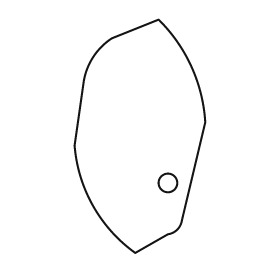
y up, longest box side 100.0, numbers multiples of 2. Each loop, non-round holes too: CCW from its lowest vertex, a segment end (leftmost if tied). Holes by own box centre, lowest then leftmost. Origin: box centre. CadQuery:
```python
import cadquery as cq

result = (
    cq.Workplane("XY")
    .moveTo(-2.0, -50.0)
    .lineTo(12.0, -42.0)
    .threePointArc((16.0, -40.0), (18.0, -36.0))
    .lineTo(28.0, 6.0)
    .threePointArc((22.0, 30.0), (8.0, 50.0))
    .lineTo(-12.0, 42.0)
    .threePointArc((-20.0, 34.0), (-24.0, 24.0))
    .lineTo(-28.0, -4.0)
    .threePointArc((-20.0, -30.0), (-2.0, -50.0))
    .close()
    .moveTo(12.0, -20.0)
    .circle(4.0)
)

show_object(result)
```